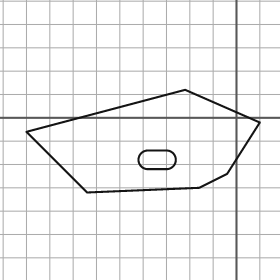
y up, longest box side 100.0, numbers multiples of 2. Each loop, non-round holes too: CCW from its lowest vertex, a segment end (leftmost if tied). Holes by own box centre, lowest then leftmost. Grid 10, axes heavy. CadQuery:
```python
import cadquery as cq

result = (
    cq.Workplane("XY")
    .moveTo(-64.0, -32.0)
    .lineTo(-16.0, -30.0)
    .lineTo(-4.0, -24.0)
    .lineTo(10.0, -2.0)
    .lineTo(-22.0, 12.0)
    .lineTo(-90.0, -6.0)
    .close()
    .moveTo(-38.0, -22.0)
    .lineTo(-30.0, -22.0)
    .threePointArc((-26.0, -18.0), (-30.0, -14.0))
    .lineTo(-38.0, -14.0)
    .threePointArc((-42.0, -18.0), (-38.0, -22.0))
    .close()
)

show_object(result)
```